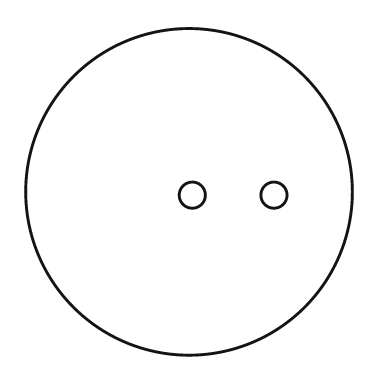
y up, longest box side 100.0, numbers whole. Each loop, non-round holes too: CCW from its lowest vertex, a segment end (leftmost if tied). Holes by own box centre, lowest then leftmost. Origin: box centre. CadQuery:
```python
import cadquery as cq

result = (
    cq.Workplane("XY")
    .moveTo(0.0, 0.0)
    .circle(50.0)
    .moveTo(1.0, -1.0)
    .circle(4.0)
    .moveTo(26.0, -1.0)
    .circle(4.0)
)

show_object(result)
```